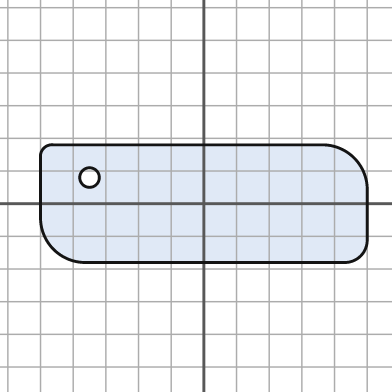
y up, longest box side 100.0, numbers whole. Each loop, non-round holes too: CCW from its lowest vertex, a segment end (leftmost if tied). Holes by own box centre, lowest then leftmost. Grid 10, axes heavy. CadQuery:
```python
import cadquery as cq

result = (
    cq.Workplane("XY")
    .moveTo(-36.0, -18.0)
    .lineTo(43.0, -18.0)
    .threePointArc((48.0, -16.0), (50.0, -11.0))
    .lineTo(50.0, 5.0)
    .threePointArc((46.0, 14.0), (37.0, 18.0))
    .lineTo(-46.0, 18.0)
    .threePointArc((-49.0, 17.0), (-50.0, 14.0))
    .lineTo(-50.0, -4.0)
    .threePointArc((-46.0, -14.0), (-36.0, -18.0))
    .close()
    .moveTo(-35.0, 8.0)
    .circle(3.0)
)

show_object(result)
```